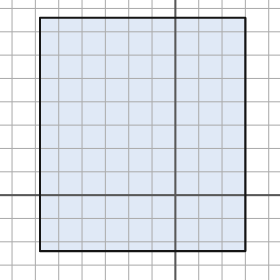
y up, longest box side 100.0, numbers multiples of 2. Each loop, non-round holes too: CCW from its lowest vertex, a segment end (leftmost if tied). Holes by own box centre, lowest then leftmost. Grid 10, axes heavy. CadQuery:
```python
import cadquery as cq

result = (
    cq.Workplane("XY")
    .moveTo(-58.0, -24.0)
    .lineTo(30.0, -24.0)
    .lineTo(30.0, 76.0)
    .lineTo(-58.0, 76.0)
    .close()
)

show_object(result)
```